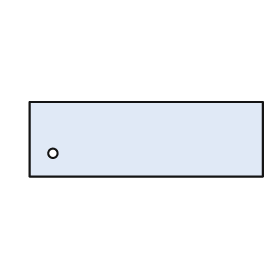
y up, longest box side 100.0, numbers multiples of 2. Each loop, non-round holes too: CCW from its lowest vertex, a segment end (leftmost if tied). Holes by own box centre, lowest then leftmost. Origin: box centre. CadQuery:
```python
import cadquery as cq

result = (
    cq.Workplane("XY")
    .moveTo(-50.0, -16.0)
    .lineTo(50.0, -16.0)
    .lineTo(50.0, 16.0)
    .lineTo(-50.0, 16.0)
    .close()
    .moveTo(-40.0, -6.0)
    .circle(2.0)
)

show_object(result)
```